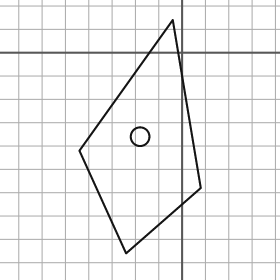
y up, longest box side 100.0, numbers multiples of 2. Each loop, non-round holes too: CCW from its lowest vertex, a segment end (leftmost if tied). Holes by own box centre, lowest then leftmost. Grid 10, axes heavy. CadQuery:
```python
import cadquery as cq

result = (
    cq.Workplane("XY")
    .moveTo(-24.0, -86.0)
    .lineTo(8.0, -58.0)
    .lineTo(-4.0, 14.0)
    .lineTo(-44.0, -42.0)
    .close()
    .moveTo(-18.0, -36.0)
    .circle(4.0)
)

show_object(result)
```